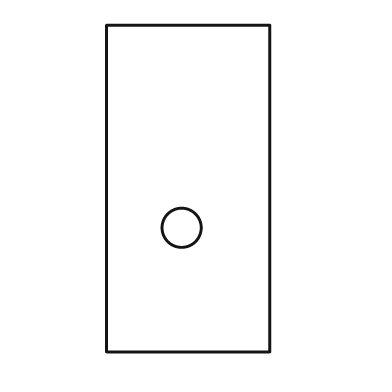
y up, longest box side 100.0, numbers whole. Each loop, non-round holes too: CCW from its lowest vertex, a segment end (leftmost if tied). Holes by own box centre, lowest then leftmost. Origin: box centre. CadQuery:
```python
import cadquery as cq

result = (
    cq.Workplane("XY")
    .moveTo(-25.0, -50.0)
    .lineTo(25.0, -50.0)
    .lineTo(25.0, 50.0)
    .lineTo(-25.0, 50.0)
    .close()
    .moveTo(-2.0, -12.0)
    .circle(6.0)
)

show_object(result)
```